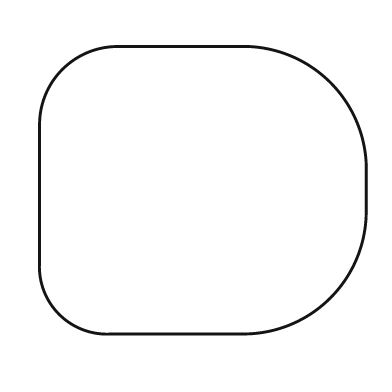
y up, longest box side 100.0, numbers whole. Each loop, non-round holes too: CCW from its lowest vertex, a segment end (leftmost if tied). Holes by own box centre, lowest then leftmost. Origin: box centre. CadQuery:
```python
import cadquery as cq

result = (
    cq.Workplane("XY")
    .moveTo(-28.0, -44.0)
    .lineTo(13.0, -44.0)
    .threePointArc((39.0, -33.0), (50.0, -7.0))
    .lineTo(50.0, 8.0)
    .threePointArc((39.0, 33.0), (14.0, 44.0))
    .lineTo(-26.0, 44.0)
    .threePointArc((-43.0, 37.0), (-50.0, 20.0))
    .lineTo(-50.0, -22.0)
    .threePointArc((-44.0, -38.0), (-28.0, -44.0))
    .close()
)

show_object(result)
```